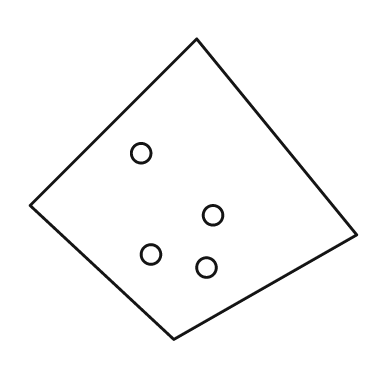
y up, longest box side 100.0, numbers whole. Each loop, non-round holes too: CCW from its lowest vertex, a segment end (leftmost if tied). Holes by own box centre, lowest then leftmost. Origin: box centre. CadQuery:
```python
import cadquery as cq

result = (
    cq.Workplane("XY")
    .moveTo(-6.0, -46.0)
    .lineTo(50.0, -14.0)
    .lineTo(1.0, 46.0)
    .lineTo(-50.0, -5.0)
    .close()
    .moveTo(4.0, -24.0)
    .circle(3.0)
    .moveTo(-13.0, -20.0)
    .circle(3.0)
    .moveTo(6.0, -8.0)
    .circle(3.0)
    .moveTo(-16.0, 11.0)
    .circle(3.0)
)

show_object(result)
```